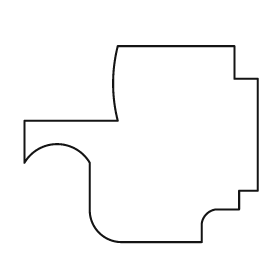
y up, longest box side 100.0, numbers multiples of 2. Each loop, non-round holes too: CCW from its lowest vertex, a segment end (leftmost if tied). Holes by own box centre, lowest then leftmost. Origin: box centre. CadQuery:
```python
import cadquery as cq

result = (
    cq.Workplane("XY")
    .moveTo(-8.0, -42.0)
    .lineTo(26.0, -42.0)
    .lineTo(26.0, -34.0)
    .threePointArc((28.0, -30.0), (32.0, -28.0))
    .lineTo(42.0, -28.0)
    .lineTo(42.0, -20.0)
    .lineTo(50.0, -20.0)
    .lineTo(50.0, 28.0)
    .lineTo(40.0, 28.0)
    .lineTo(40.0, 42.0)
    .lineTo(-10.0, 42.0)
    .threePointArc((-12.0, 26.0), (-10.0, 10.0))
    .lineTo(-50.0, 10.0)
    .lineTo(-50.0, -8.0)
    .threePointArc((-36.0, 0.0), (-22.0, -8.0))
    .lineTo(-22.0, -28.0)
    .threePointArc((-18.0, -38.0), (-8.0, -42.0))
    .close()
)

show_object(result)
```